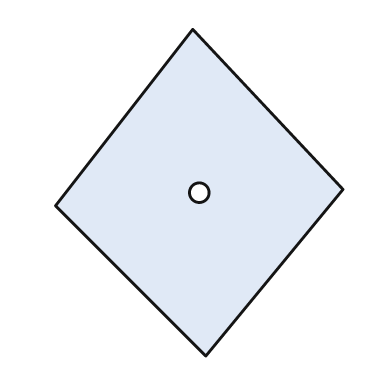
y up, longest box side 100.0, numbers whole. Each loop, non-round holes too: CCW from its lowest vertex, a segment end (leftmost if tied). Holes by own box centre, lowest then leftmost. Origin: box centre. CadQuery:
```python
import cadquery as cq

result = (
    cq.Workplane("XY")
    .moveTo(2.0, -50.0)
    .lineTo(44.0, 1.0)
    .lineTo(-2.0, 50.0)
    .lineTo(-44.0, -4.0)
    .close()
    .moveTo(0.0, 0.0)
    .circle(3.0)
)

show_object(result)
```